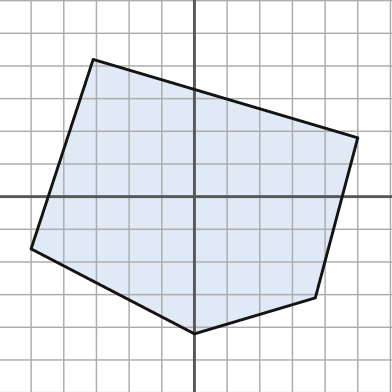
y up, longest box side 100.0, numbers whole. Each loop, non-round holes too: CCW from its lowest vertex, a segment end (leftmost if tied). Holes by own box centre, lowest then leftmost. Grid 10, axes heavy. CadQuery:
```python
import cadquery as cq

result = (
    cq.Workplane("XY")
    .moveTo(0.0, -42.0)
    .lineTo(37.0, -31.0)
    .lineTo(50.0, 18.0)
    .lineTo(-31.0, 42.0)
    .lineTo(-50.0, -16.0)
    .close()
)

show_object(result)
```